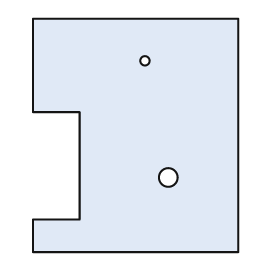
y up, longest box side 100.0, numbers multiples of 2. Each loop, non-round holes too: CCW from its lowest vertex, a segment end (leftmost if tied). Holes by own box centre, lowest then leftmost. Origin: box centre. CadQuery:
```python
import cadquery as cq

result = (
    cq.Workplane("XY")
    .moveTo(-44.0, -50.0)
    .lineTo(44.0, -50.0)
    .lineTo(44.0, 50.0)
    .lineTo(-44.0, 50.0)
    .lineTo(-44.0, 10.0)
    .lineTo(-24.0, 10.0)
    .lineTo(-24.0, -36.0)
    .lineTo(-44.0, -36.0)
    .close()
    .moveTo(14.0, -18.0)
    .circle(4.0)
    .moveTo(4.0, 32.0)
    .circle(2.0)
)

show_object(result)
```